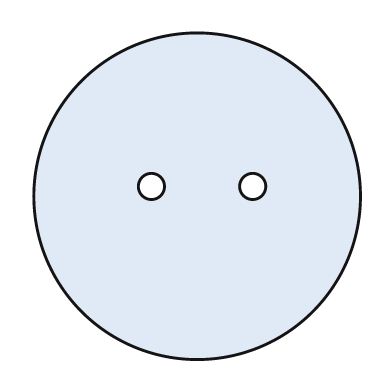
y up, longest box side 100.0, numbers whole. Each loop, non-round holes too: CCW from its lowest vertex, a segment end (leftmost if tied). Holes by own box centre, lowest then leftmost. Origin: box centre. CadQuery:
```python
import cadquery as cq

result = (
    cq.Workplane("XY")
    .moveTo(0.0, 0.0)
    .circle(50.0)
    .moveTo(-14.0, 3.0)
    .circle(4.0)
    .moveTo(17.0, 3.0)
    .circle(4.0)
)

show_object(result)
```